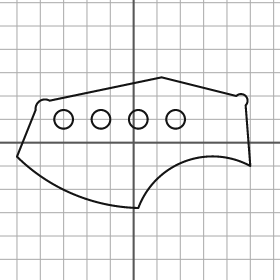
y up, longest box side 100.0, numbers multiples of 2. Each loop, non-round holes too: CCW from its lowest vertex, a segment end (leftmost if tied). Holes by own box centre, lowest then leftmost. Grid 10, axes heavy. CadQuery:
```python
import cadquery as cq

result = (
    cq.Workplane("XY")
    .moveTo(2.0, -28.0)
    .threePointArc((22.0, -8.0), (50.0, -10.0))
    .lineTo(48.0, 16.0)
    .threePointArc((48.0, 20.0), (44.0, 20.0))
    .lineTo(12.0, 28.0)
    .lineTo(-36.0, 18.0)
    .threePointArc((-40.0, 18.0), (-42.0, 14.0))
    .lineTo(-50.0, -6.0)
    .threePointArc((-26.0, -22.0), (2.0, -28.0))
    .close()
    .moveTo(-30.0, 10.0)
    .circle(4.0)
    .moveTo(-14.0, 10.0)
    .circle(4.0)
    .moveTo(2.0, 10.0)
    .circle(4.0)
    .moveTo(18.0, 10.0)
    .circle(4.0)
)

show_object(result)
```